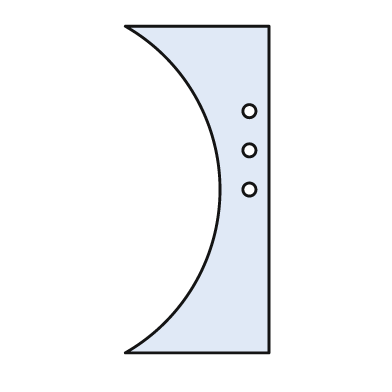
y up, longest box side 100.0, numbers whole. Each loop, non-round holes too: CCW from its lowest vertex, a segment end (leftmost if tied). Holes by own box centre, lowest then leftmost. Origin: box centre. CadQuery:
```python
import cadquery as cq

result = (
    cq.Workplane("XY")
    .moveTo(-22.0, -50.0)
    .lineTo(22.0, -50.0)
    .lineTo(22.0, 50.0)
    .lineTo(-22.0, 50.0)
    .threePointArc((7.0, 0.0), (-22.0, -50.0))
    .close()
    .moveTo(16.0, 0.0)
    .circle(2.0)
    .moveTo(16.0, 12.0)
    .circle(2.0)
    .moveTo(16.0, 24.0)
    .circle(2.0)
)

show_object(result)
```